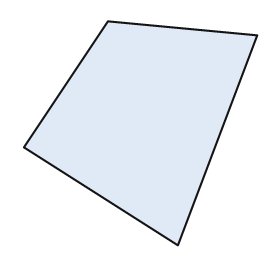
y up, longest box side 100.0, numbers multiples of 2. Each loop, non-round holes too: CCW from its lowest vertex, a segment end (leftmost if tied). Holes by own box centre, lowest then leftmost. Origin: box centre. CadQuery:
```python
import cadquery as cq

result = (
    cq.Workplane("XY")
    .moveTo(16.0, -48.0)
    .lineTo(50.0, 42.0)
    .lineTo(-14.0, 48.0)
    .lineTo(-50.0, -6.0)
    .close()
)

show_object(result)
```